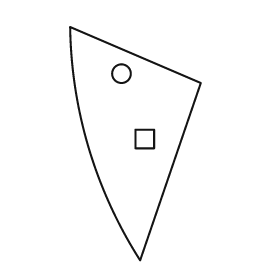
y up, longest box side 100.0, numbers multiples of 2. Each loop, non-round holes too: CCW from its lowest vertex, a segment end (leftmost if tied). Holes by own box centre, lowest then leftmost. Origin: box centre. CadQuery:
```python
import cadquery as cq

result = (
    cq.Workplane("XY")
    .moveTo(2.0, -50.0)
    .lineTo(28.0, 26.0)
    .lineTo(-28.0, 50.0)
    .threePointArc((-20.0, -2.0), (2.0, -50.0))
    .close()
    .moveTo(0.0, -2.0)
    .lineTo(8.0, -2.0)
    .lineTo(8.0, 6.0)
    .lineTo(0.0, 6.0)
    .close()
    .moveTo(-6.0, 30.0)
    .circle(4.0)
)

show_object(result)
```